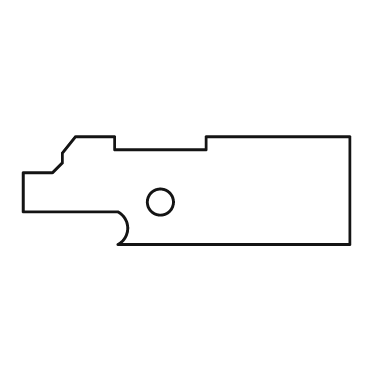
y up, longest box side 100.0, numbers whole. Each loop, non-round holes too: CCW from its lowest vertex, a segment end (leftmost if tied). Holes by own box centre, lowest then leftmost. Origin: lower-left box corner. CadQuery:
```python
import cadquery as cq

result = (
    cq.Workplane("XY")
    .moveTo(29.0, 0.0)
    .lineTo(100.0, 0.0)
    .lineTo(100.0, 33.0)
    .lineTo(56.0, 33.0)
    .lineTo(56.0, 29.0)
    .lineTo(28.0, 29.0)
    .lineTo(28.0, 33.0)
    .lineTo(16.0, 33.0)
    .lineTo(12.0, 28.0)
    .lineTo(12.0, 25.0)
    .lineTo(9.0, 22.0)
    .lineTo(0.0, 22.0)
    .lineTo(0.0, 10.0)
    .lineTo(29.0, 10.0)
    .threePointArc((32.0, 5.0), (29.0, 0.0))
    .close()
    .moveTo(42.0, 13.0)
    .circle(4.0)
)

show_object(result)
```